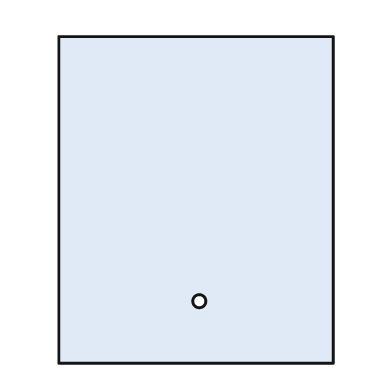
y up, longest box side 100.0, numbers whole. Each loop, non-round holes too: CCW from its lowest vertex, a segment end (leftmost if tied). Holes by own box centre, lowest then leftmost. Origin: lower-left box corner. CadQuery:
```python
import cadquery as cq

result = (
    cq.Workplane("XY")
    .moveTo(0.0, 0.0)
    .lineTo(84.0, 0.0)
    .lineTo(84.0, 100.0)
    .lineTo(0.0, 100.0)
    .close()
    .moveTo(43.0, 19.0)
    .circle(2.0)
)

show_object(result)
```